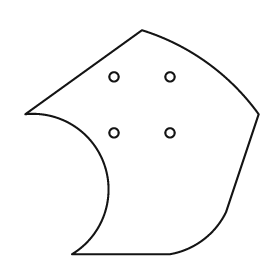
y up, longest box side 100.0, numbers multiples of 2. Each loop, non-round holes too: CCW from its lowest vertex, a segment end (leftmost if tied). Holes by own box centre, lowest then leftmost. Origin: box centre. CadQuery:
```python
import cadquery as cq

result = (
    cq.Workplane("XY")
    .moveTo(-30.0, -48.0)
    .lineTo(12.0, -48.0)
    .threePointArc((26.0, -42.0), (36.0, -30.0))
    .lineTo(50.0, 12.0)
    .threePointArc((28.0, 34.0), (0.0, 48.0))
    .lineTo(-50.0, 12.0)
    .threePointArc((-16.0, -10.0), (-30.0, -48.0))
    .close()
    .moveTo(-12.0, 4.0)
    .circle(2.0)
    .moveTo(12.0, 4.0)
    .circle(2.0)
    .moveTo(-12.0, 28.0)
    .circle(2.0)
    .moveTo(12.0, 28.0)
    .circle(2.0)
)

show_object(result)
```